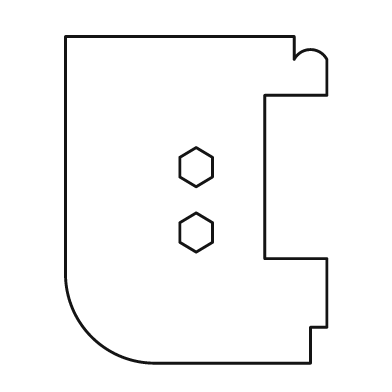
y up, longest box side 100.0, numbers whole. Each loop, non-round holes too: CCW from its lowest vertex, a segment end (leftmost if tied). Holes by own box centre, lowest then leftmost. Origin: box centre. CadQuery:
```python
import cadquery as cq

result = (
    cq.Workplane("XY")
    .moveTo(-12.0, -50.0)
    .lineTo(35.0, -50.0)
    .lineTo(35.0, -39.0)
    .lineTo(40.0, -39.0)
    .lineTo(40.0, -18.0)
    .lineTo(21.0, -18.0)
    .lineTo(21.0, 32.0)
    .lineTo(40.0, 32.0)
    .lineTo(40.0, 43.0)
    .threePointArc((35.0, 46.0), (30.0, 43.0))
    .lineTo(30.0, 50.0)
    .lineTo(-40.0, 50.0)
    .lineTo(-40.0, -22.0)
    .threePointArc((-32.0, -42.0), (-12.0, -50.0))
    .close()
    .moveTo(0.0, -16.0)
    .lineTo(5.0, -13.0)
    .lineTo(5.0, -7.0)
    .lineTo(0.0, -4.0)
    .lineTo(-5.0, -7.0)
    .lineTo(-5.0, -13.0)
    .close()
    .moveTo(0.0, 4.0)
    .lineTo(5.0, 7.0)
    .lineTo(5.0, 13.0)
    .lineTo(0.0, 16.0)
    .lineTo(-5.0, 13.0)
    .lineTo(-5.0, 7.0)
    .close()
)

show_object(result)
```